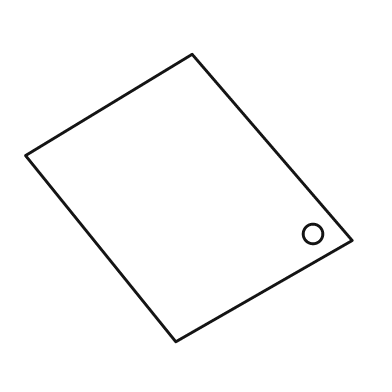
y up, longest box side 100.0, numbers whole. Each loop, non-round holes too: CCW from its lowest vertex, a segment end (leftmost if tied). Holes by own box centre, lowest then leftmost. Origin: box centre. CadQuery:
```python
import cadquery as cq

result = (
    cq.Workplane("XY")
    .moveTo(-4.0, -44.0)
    .lineTo(50.0, -13.0)
    .lineTo(1.0, 44.0)
    .lineTo(-50.0, 13.0)
    .close()
    .moveTo(38.0, -11.0)
    .circle(3.0)
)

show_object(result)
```